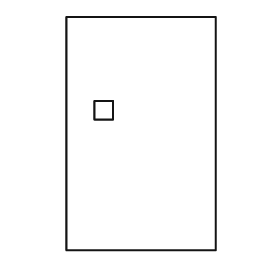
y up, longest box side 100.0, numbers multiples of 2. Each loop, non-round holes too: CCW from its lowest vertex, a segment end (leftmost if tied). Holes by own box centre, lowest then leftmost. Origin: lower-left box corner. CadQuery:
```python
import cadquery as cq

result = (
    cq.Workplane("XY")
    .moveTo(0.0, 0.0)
    .lineTo(64.0, 0.0)
    .lineTo(64.0, 100.0)
    .lineTo(0.0, 100.0)
    .close()
    .moveTo(12.0, 56.0)
    .lineTo(20.0, 56.0)
    .lineTo(20.0, 64.0)
    .lineTo(12.0, 64.0)
    .close()
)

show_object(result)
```